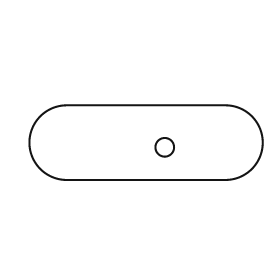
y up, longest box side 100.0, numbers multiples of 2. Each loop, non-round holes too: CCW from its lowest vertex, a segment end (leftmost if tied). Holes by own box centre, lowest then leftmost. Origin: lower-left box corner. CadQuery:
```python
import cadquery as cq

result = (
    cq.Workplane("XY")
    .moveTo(16.0, 0.0)
    .lineTo(84.0, 0.0)
    .threePointArc((100.0, 16.0), (84.0, 32.0))
    .lineTo(16.0, 32.0)
    .threePointArc((0.0, 16.0), (16.0, 0.0))
    .close()
    .moveTo(58.0, 14.0)
    .circle(4.0)
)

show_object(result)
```